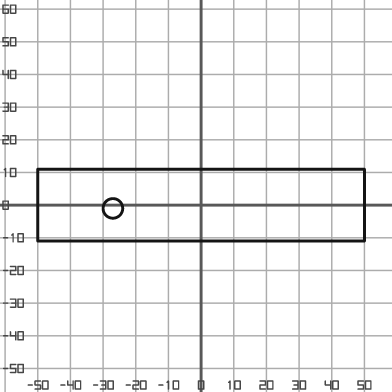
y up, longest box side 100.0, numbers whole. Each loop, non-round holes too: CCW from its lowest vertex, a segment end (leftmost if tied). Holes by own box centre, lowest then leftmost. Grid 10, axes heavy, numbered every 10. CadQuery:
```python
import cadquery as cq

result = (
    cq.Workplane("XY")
    .moveTo(-50.0, -11.0)
    .lineTo(50.0, -11.0)
    .lineTo(50.0, 11.0)
    .lineTo(-50.0, 11.0)
    .close()
    .moveTo(-27.0, -1.0)
    .circle(3.0)
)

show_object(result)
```